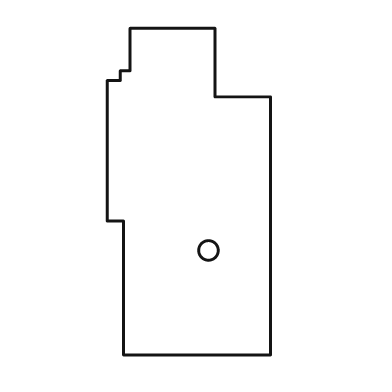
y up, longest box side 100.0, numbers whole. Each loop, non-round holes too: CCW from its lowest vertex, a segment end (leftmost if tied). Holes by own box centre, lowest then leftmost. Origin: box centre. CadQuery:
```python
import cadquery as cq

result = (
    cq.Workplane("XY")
    .moveTo(-20.0, -50.0)
    .lineTo(25.0, -50.0)
    .lineTo(25.0, 29.0)
    .lineTo(8.0, 29.0)
    .lineTo(8.0, 50.0)
    .lineTo(-18.0, 50.0)
    .lineTo(-18.0, 37.0)
    .lineTo(-21.0, 37.0)
    .lineTo(-21.0, 34.0)
    .lineTo(-25.0, 34.0)
    .lineTo(-25.0, -9.0)
    .lineTo(-20.0, -9.0)
    .close()
    .moveTo(6.0, -18.0)
    .circle(3.0)
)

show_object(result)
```